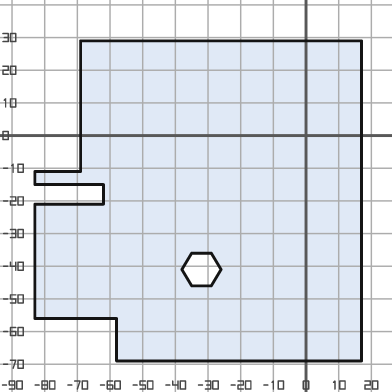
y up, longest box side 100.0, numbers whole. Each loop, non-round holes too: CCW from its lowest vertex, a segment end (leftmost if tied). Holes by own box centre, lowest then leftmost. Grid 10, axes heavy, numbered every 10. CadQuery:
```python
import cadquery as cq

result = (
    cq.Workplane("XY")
    .moveTo(-58.0, -69.0)
    .lineTo(17.0, -69.0)
    .lineTo(17.0, 29.0)
    .lineTo(-69.0, 29.0)
    .lineTo(-69.0, -11.0)
    .lineTo(-83.0, -11.0)
    .lineTo(-83.0, -15.0)
    .lineTo(-62.0, -15.0)
    .lineTo(-62.0, -21.0)
    .lineTo(-83.0, -21.0)
    .lineTo(-83.0, -56.0)
    .lineTo(-58.0, -56.0)
    .close()
    .moveTo(-35.0, -46.0)
    .lineTo(-29.0, -46.0)
    .lineTo(-26.0, -41.0)
    .lineTo(-29.0, -36.0)
    .lineTo(-35.0, -36.0)
    .lineTo(-38.0, -41.0)
    .close()
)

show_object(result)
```